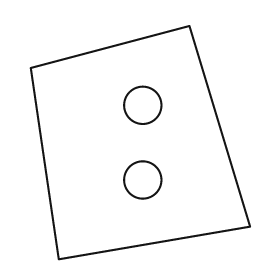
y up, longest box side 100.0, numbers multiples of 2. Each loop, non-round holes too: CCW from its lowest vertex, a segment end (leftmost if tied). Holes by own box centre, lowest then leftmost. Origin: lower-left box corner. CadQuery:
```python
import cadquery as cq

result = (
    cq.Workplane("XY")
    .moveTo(12.0, 0.0)
    .lineTo(94.0, 14.0)
    .lineTo(68.0, 100.0)
    .lineTo(0.0, 82.0)
    .close()
    .moveTo(48.0, 34.0)
    .circle(8.0)
    .moveTo(48.0, 66.0)
    .circle(8.0)
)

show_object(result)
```